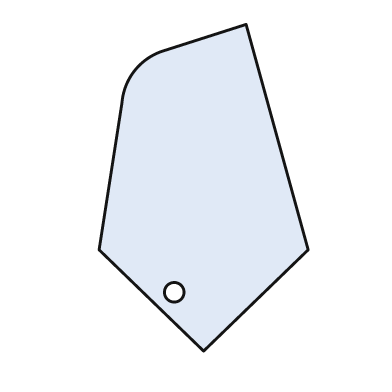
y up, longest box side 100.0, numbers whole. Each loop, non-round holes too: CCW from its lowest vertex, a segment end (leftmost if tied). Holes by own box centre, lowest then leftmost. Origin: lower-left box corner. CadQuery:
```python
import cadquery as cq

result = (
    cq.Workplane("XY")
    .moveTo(32.0, 0.0)
    .lineTo(64.0, 31.0)
    .lineTo(45.0, 100.0)
    .lineTo(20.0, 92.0)
    .threePointArc((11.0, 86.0), (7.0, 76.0))
    .lineTo(0.0, 31.0)
    .close()
    .moveTo(23.0, 18.0)
    .circle(3.0)
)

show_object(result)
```